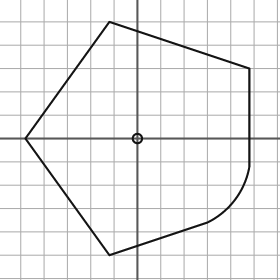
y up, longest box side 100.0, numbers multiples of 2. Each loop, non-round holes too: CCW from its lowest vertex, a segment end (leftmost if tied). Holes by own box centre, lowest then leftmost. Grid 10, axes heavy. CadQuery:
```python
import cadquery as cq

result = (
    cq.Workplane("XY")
    .moveTo(-12.0, -50.0)
    .lineTo(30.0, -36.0)
    .threePointArc((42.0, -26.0), (48.0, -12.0))
    .lineTo(48.0, 30.0)
    .lineTo(-12.0, 50.0)
    .lineTo(-48.0, 0.0)
    .close()
    .moveTo(0.0, 0.0)
    .circle(2.0)
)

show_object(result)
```